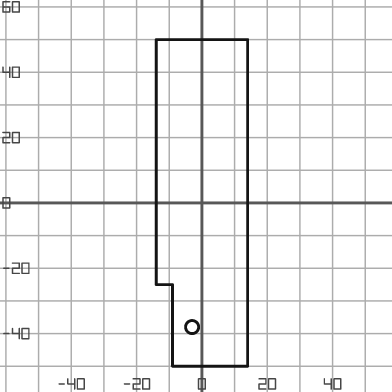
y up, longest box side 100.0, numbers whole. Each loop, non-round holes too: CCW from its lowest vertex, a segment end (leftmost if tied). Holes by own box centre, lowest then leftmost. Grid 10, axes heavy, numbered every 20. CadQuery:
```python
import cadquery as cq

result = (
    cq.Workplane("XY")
    .moveTo(-9.0, -50.0)
    .lineTo(14.0, -50.0)
    .lineTo(14.0, 50.0)
    .lineTo(-14.0, 50.0)
    .lineTo(-14.0, -25.0)
    .lineTo(-9.0, -25.0)
    .close()
    .moveTo(-3.0, -38.0)
    .circle(2.0)
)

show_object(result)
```